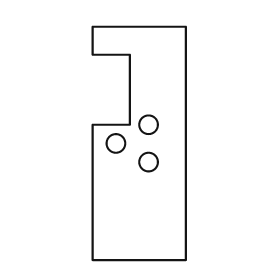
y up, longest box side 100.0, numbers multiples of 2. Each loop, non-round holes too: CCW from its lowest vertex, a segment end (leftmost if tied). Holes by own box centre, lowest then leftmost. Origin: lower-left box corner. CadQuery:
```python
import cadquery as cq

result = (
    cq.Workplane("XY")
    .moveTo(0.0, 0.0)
    .lineTo(40.0, 0.0)
    .lineTo(40.0, 100.0)
    .lineTo(0.0, 100.0)
    .lineTo(0.0, 88.0)
    .lineTo(16.0, 88.0)
    .lineTo(16.0, 58.0)
    .lineTo(0.0, 58.0)
    .close()
    .moveTo(24.0, 42.0)
    .circle(4.0)
    .moveTo(10.0, 50.0)
    .circle(4.0)
    .moveTo(24.0, 58.0)
    .circle(4.0)
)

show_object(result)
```